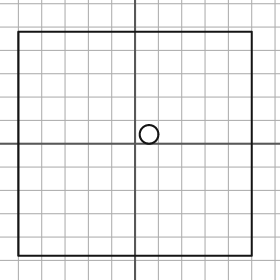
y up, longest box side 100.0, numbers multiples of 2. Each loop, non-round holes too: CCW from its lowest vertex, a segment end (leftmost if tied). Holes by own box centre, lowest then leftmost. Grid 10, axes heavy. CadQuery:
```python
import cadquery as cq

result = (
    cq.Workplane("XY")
    .moveTo(-50.0, -48.0)
    .lineTo(50.0, -48.0)
    .lineTo(50.0, 48.0)
    .lineTo(-50.0, 48.0)
    .close()
    .moveTo(6.0, 4.0)
    .circle(4.0)
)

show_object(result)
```